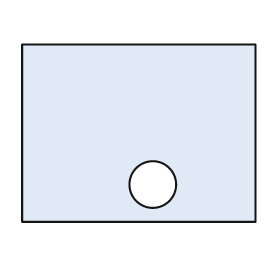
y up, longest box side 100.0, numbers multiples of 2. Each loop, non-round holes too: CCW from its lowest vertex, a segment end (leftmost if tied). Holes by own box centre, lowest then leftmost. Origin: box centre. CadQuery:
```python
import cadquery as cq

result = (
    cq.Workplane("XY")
    .moveTo(-50.0, -38.0)
    .lineTo(50.0, -38.0)
    .lineTo(50.0, 38.0)
    .lineTo(-50.0, 38.0)
    .close()
    .moveTo(6.0, -22.0)
    .circle(10.0)
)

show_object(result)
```